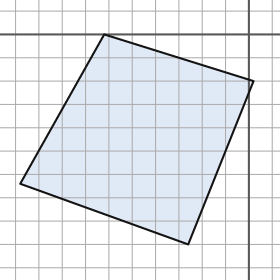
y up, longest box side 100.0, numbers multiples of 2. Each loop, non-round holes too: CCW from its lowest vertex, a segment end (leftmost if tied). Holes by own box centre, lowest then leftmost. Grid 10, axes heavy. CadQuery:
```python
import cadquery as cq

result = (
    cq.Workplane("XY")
    .moveTo(-26.0, -90.0)
    .lineTo(2.0, -20.0)
    .lineTo(-62.0, 0.0)
    .lineTo(-98.0, -64.0)
    .close()
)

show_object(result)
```